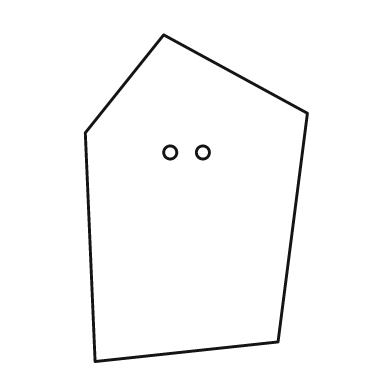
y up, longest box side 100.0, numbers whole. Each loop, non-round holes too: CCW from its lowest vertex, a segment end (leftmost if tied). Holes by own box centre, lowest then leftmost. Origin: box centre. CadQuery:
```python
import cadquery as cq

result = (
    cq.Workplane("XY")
    .moveTo(-31.0, -50.0)
    .lineTo(25.0, -44.0)
    .lineTo(34.0, 26.0)
    .lineTo(-10.0, 50.0)
    .lineTo(-34.0, 20.0)
    .close()
    .moveTo(-8.0, 14.0)
    .circle(2.0)
    .moveTo(2.0, 14.0)
    .circle(2.0)
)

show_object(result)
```